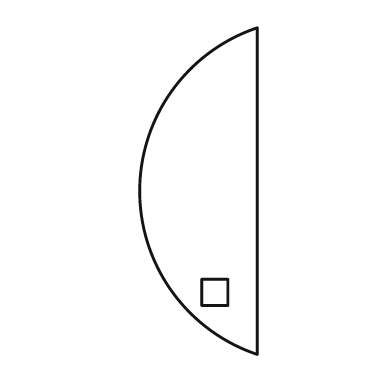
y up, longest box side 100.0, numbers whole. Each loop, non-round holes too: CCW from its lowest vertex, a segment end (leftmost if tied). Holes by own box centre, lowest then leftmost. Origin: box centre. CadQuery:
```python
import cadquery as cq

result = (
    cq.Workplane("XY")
    .moveTo(18.0, -50.0)
    .lineTo(18.0, 50.0)
    .threePointArc((-18.0, 0.0), (18.0, -50.0))
    .close()
    .moveTo(1.0, -35.0)
    .lineTo(9.0, -35.0)
    .lineTo(9.0, -27.0)
    .lineTo(1.0, -27.0)
    .close()
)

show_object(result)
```